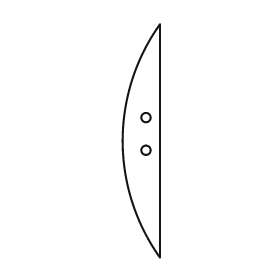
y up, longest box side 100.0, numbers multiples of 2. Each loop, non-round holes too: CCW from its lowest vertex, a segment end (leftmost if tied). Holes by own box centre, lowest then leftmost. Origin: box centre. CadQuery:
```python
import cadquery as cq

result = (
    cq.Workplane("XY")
    .moveTo(8.0, -50.0)
    .lineTo(8.0, 50.0)
    .threePointArc((-8.0, 0.0), (8.0, -50.0))
    .close()
    .moveTo(2.0, -4.0)
    .circle(2.0)
    .moveTo(2.0, 10.0)
    .circle(2.0)
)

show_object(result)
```